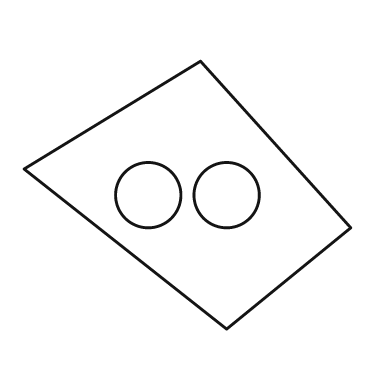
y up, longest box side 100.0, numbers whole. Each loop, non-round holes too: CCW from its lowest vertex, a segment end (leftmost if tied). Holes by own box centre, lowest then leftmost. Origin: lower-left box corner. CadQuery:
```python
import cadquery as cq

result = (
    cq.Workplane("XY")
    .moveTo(62.0, 0.0)
    .lineTo(100.0, 31.0)
    .lineTo(54.0, 82.0)
    .lineTo(0.0, 49.0)
    .close()
    .moveTo(38.0, 41.0)
    .circle(10.0)
    .moveTo(62.0, 41.0)
    .circle(10.0)
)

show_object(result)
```